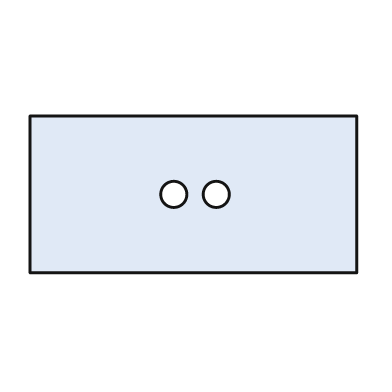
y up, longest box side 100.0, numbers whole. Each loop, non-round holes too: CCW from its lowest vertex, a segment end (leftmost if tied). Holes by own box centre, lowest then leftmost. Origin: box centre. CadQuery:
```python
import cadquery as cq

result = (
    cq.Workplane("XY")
    .moveTo(-50.0, -24.0)
    .lineTo(50.0, -24.0)
    .lineTo(50.0, 24.0)
    .lineTo(-50.0, 24.0)
    .close()
    .moveTo(-6.0, 0.0)
    .circle(4.0)
    .moveTo(7.0, 0.0)
    .circle(4.0)
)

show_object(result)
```